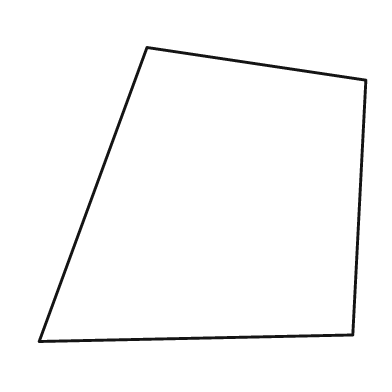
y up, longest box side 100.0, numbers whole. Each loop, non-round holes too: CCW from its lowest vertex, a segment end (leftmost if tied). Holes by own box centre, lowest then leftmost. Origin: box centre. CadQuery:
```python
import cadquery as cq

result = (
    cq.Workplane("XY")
    .moveTo(-50.0, -45.0)
    .lineTo(46.0, -43.0)
    .lineTo(50.0, 35.0)
    .lineTo(-17.0, 45.0)
    .close()
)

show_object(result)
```